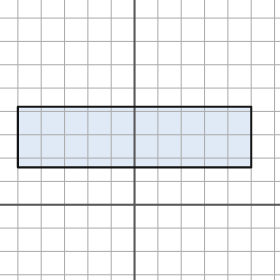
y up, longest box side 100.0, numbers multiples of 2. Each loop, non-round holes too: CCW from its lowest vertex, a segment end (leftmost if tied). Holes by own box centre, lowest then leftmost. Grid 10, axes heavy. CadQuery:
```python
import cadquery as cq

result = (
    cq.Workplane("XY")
    .moveTo(-50.0, 16.0)
    .lineTo(50.0, 16.0)
    .lineTo(50.0, 42.0)
    .lineTo(-50.0, 42.0)
    .close()
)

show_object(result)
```